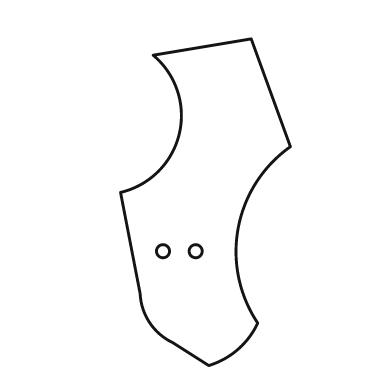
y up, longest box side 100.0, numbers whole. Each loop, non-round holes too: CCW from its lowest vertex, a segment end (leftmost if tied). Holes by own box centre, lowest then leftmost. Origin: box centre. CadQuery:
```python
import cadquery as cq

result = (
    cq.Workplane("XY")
    .moveTo(1.0, -50.0)
    .threePointArc((10.0, -45.0), (16.0, -37.0))
    .threePointArc((10.0, -8.0), (26.0, 17.0))
    .lineTo(14.0, 50.0)
    .lineTo(-16.0, 45.0)
    .threePointArc((-8.0, 21.0), (-26.0, 3.0))
    .lineTo(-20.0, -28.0)
    .threePointArc((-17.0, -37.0), (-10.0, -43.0))
    .close()
    .moveTo(-13.0, -15.0)
    .circle(2.0)
    .moveTo(-3.0, -15.0)
    .circle(2.0)
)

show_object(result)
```